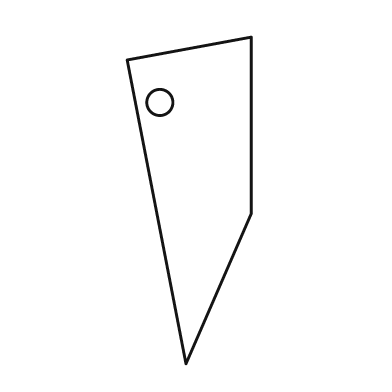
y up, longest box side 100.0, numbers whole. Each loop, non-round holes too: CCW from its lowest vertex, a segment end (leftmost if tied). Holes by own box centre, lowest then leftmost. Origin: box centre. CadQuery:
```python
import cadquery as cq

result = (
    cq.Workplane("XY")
    .moveTo(-1.0, -50.0)
    .lineTo(19.0, -4.0)
    .lineTo(19.0, 50.0)
    .lineTo(-19.0, 43.0)
    .close()
    .moveTo(-9.0, 30.0)
    .circle(4.0)
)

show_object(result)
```